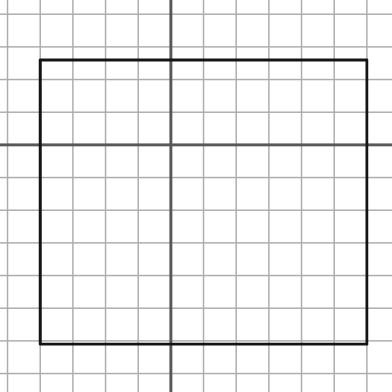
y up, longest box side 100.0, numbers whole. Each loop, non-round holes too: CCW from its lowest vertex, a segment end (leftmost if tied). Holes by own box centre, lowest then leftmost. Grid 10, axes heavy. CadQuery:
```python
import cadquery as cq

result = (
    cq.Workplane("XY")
    .moveTo(-40.0, -61.0)
    .lineTo(60.0, -61.0)
    .lineTo(60.0, 26.0)
    .lineTo(-40.0, 26.0)
    .close()
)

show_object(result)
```